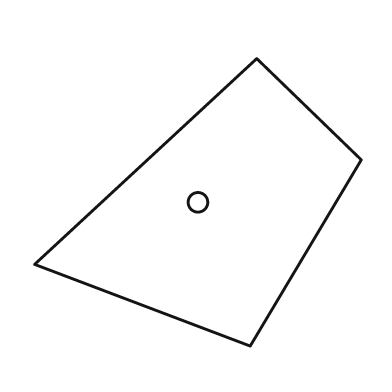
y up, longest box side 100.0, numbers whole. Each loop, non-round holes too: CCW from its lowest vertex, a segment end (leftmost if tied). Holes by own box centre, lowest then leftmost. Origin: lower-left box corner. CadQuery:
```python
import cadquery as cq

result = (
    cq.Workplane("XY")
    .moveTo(66.0, 0.0)
    .lineTo(100.0, 57.0)
    .lineTo(68.0, 88.0)
    .lineTo(0.0, 25.0)
    .close()
    .moveTo(50.0, 44.0)
    .circle(3.0)
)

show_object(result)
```